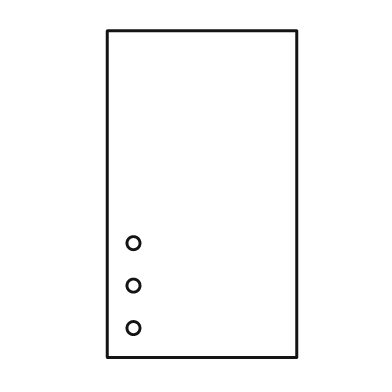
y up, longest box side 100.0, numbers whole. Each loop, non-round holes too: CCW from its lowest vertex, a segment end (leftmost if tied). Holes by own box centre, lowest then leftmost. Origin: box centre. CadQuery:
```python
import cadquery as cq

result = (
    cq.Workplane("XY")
    .moveTo(-29.0, -50.0)
    .lineTo(29.0, -50.0)
    .lineTo(29.0, 50.0)
    .lineTo(-29.0, 50.0)
    .close()
    .moveTo(-21.0, -41.0)
    .circle(2.0)
    .moveTo(-21.0, -28.0)
    .circle(2.0)
    .moveTo(-21.0, -15.0)
    .circle(2.0)
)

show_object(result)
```